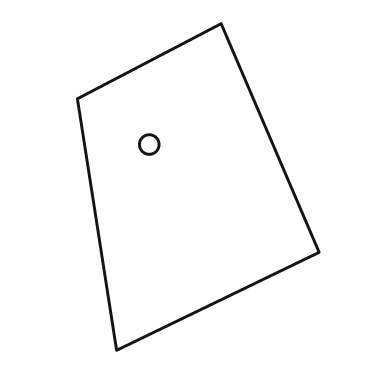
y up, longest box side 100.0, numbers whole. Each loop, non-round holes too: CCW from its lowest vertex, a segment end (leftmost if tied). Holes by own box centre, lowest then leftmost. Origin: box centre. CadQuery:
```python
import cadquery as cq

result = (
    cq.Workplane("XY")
    .moveTo(-25.0, -50.0)
    .lineTo(37.0, -20.0)
    .lineTo(7.0, 50.0)
    .lineTo(-37.0, 27.0)
    .close()
    .moveTo(-15.0, 13.0)
    .circle(3.0)
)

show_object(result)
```